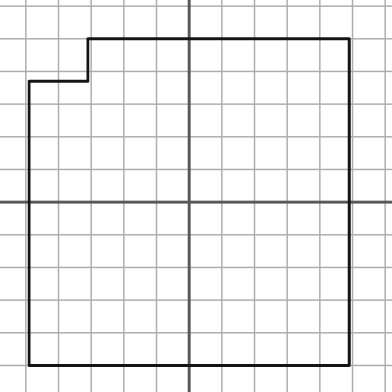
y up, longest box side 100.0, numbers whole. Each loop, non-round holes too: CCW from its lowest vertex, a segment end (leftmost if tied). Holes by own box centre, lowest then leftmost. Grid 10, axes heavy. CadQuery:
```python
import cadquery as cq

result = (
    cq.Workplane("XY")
    .moveTo(-49.0, -50.0)
    .lineTo(49.0, -50.0)
    .lineTo(49.0, 50.0)
    .lineTo(-31.0, 50.0)
    .lineTo(-31.0, 37.0)
    .lineTo(-49.0, 37.0)
    .close()
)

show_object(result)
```